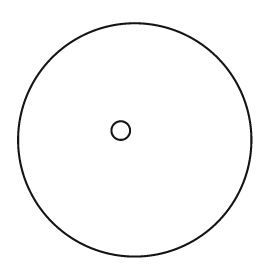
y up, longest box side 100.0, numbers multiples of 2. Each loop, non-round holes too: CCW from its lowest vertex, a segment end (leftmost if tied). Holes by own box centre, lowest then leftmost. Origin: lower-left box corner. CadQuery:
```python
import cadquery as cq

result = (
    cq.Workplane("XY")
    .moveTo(50.0, 50.0)
    .circle(50.0)
    .moveTo(44.0, 54.0)
    .circle(4.0)
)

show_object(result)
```